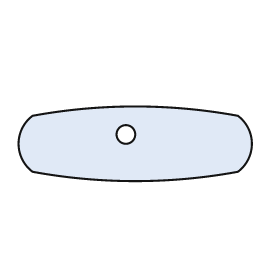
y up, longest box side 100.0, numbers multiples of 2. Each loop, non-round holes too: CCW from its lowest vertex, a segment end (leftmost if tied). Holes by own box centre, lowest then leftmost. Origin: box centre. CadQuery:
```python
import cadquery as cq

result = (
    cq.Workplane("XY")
    .moveTo(-44.0, -12.0)
    .threePointArc((0.0, -16.0), (44.0, -12.0))
    .threePointArc((50.0, 0.0), (44.0, 12.0))
    .threePointArc((0.0, 16.0), (-44.0, 12.0))
    .threePointArc((-50.0, 0.0), (-44.0, -12.0))
    .close()
    .moveTo(-4.0, 4.0)
    .circle(4.0)
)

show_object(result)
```